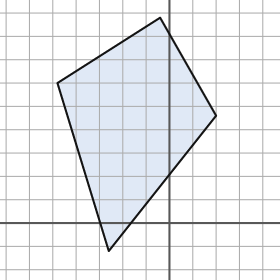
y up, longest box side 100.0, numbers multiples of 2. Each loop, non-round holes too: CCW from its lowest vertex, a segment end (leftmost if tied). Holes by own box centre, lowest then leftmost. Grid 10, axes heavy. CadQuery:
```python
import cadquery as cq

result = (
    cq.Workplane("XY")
    .moveTo(-26.0, -12.0)
    .lineTo(20.0, 46.0)
    .lineTo(-4.0, 88.0)
    .lineTo(-48.0, 60.0)
    .close()
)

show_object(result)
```